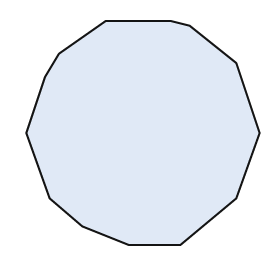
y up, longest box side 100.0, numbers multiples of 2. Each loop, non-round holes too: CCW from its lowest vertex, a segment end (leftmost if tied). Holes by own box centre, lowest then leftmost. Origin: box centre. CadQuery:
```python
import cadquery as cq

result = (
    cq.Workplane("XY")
    .moveTo(-6.0, -48.0)
    .lineTo(16.0, -48.0)
    .lineTo(40.0, -28.0)
    .lineTo(50.0, 0.0)
    .lineTo(40.0, 30.0)
    .lineTo(20.0, 46.0)
    .lineTo(12.0, 48.0)
    .lineTo(-16.0, 48.0)
    .lineTo(-36.0, 34.0)
    .lineTo(-42.0, 24.0)
    .lineTo(-50.0, 0.0)
    .lineTo(-40.0, -28.0)
    .lineTo(-26.0, -40.0)
    .close()
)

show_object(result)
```